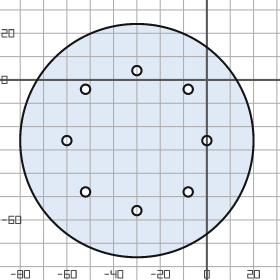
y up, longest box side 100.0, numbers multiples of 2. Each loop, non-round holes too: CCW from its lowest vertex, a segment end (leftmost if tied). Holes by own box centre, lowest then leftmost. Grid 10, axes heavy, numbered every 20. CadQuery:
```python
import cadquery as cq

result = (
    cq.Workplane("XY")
    .moveTo(-30.0, -26.0)
    .circle(50.0)
    .moveTo(-30.0, -56.0)
    .circle(2.0)
    .moveTo(-52.0, -48.0)
    .circle(2.0)
    .moveTo(-8.0, -48.0)
    .circle(2.0)
    .moveTo(-60.0, -26.0)
    .circle(2.0)
    .moveTo(0.0, -26.0)
    .circle(2.0)
    .moveTo(-52.0, -4.0)
    .circle(2.0)
    .moveTo(-8.0, -4.0)
    .circle(2.0)
    .moveTo(-30.0, 4.0)
    .circle(2.0)
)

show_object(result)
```